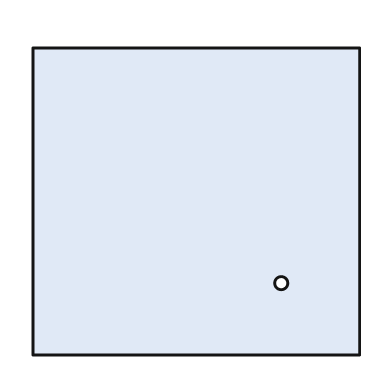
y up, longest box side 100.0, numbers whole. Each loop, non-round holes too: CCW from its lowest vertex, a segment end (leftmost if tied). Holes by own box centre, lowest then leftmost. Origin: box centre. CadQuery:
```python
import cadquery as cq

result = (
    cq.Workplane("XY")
    .moveTo(-50.0, -47.0)
    .lineTo(50.0, -47.0)
    .lineTo(50.0, 47.0)
    .lineTo(-50.0, 47.0)
    .close()
    .moveTo(26.0, -25.0)
    .circle(2.0)
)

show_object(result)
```